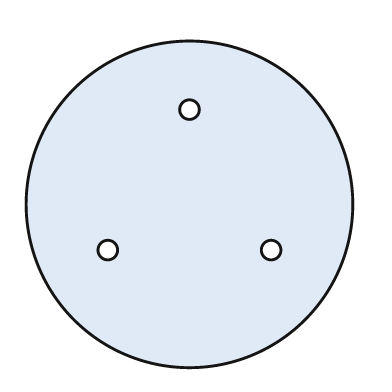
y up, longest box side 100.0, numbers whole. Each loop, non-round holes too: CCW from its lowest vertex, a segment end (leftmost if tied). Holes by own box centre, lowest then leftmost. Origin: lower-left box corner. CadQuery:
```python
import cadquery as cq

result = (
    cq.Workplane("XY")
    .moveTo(50.0, 50.0)
    .circle(50.0)
    .moveTo(25.0, 36.0)
    .circle(3.0)
    .moveTo(75.0, 36.0)
    .circle(3.0)
    .moveTo(50.0, 79.0)
    .circle(3.0)
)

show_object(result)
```